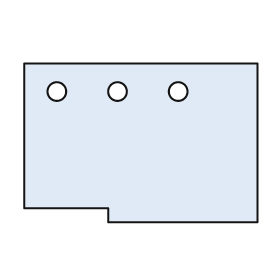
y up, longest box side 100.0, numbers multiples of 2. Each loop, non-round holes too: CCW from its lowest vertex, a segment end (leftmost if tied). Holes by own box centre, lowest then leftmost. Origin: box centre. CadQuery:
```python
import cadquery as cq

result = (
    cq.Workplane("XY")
    .moveTo(-14.0, -34.0)
    .lineTo(50.0, -34.0)
    .lineTo(50.0, 34.0)
    .lineTo(-50.0, 34.0)
    .lineTo(-50.0, -28.0)
    .lineTo(-14.0, -28.0)
    .close()
    .moveTo(-36.0, 22.0)
    .circle(4.0)
    .moveTo(-10.0, 22.0)
    .circle(4.0)
    .moveTo(16.0, 22.0)
    .circle(4.0)
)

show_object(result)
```